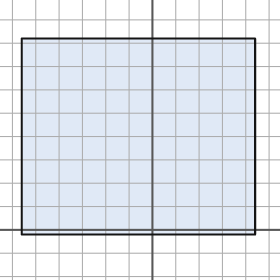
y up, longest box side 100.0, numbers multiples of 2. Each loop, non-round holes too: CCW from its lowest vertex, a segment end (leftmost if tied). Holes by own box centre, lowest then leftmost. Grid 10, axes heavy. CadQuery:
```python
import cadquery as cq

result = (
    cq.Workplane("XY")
    .moveTo(-56.0, -2.0)
    .lineTo(44.0, -2.0)
    .lineTo(44.0, 82.0)
    .lineTo(-56.0, 82.0)
    .close()
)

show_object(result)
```